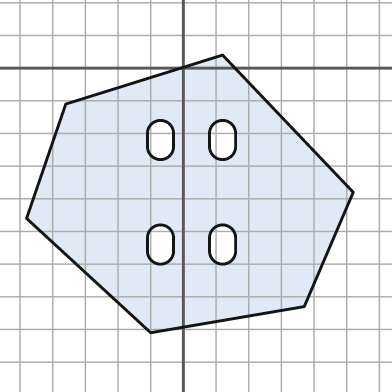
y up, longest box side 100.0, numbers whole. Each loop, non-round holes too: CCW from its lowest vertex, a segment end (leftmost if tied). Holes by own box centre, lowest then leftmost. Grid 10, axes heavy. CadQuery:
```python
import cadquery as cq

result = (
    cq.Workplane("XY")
    .moveTo(-10.0, -81.0)
    .lineTo(37.0, -73.0)
    .lineTo(52.0, -38.0)
    .lineTo(12.0, 4.0)
    .lineTo(-36.0, -11.0)
    .lineTo(-48.0, -46.0)
    .close()
    .moveTo(-11.0, -56.0)
    .threePointArc((-7.0, -60.0), (-3.0, -56.0))
    .lineTo(-3.0, -52.0)
    .threePointArc((-7.0, -48.0), (-11.0, -52.0))
    .close()
    .moveTo(8.0, -56.0)
    .threePointArc((12.0, -60.0), (16.0, -56.0))
    .lineTo(16.0, -52.0)
    .threePointArc((12.0, -48.0), (8.0, -52.0))
    .close()
    .moveTo(-11.0, -24.0)
    .threePointArc((-7.0, -28.0), (-3.0, -24.0))
    .lineTo(-3.0, -20.0)
    .threePointArc((-7.0, -16.0), (-11.0, -20.0))
    .close()
    .moveTo(8.0, -24.0)
    .threePointArc((12.0, -28.0), (16.0, -24.0))
    .lineTo(16.0, -20.0)
    .threePointArc((12.0, -16.0), (8.0, -20.0))
    .close()
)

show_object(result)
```